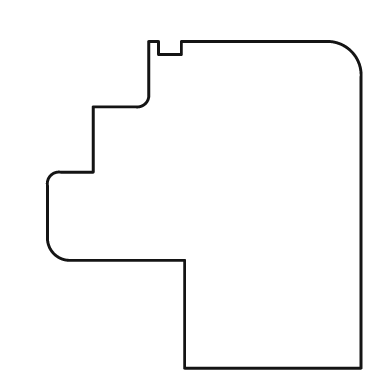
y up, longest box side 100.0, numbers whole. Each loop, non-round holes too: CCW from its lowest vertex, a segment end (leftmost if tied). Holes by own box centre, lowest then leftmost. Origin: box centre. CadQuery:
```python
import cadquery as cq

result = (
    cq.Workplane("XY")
    .moveTo(-6.0, -50.0)
    .lineTo(48.0, -50.0)
    .lineTo(48.0, 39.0)
    .threePointArc((45.0, 47.0), (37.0, 50.0))
    .lineTo(-7.0, 50.0)
    .lineTo(-7.0, 46.0)
    .lineTo(-14.0, 46.0)
    .lineTo(-14.0, 50.0)
    .lineTo(-17.0, 50.0)
    .lineTo(-17.0, 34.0)
    .threePointArc((-18.0, 31.0), (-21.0, 30.0))
    .lineTo(-34.0, 30.0)
    .lineTo(-34.0, 10.0)
    .lineTo(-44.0, 10.0)
    .threePointArc((-47.0, 9.0), (-48.0, 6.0))
    .lineTo(-48.0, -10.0)
    .threePointArc((-46.0, -15.0), (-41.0, -17.0))
    .lineTo(-6.0, -17.0)
    .close()
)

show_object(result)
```